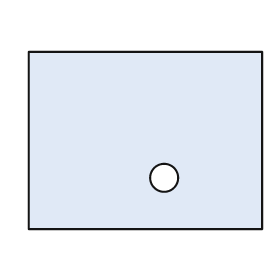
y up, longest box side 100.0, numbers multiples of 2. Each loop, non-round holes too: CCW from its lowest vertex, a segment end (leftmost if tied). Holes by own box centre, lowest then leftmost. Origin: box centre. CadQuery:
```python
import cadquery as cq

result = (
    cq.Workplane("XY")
    .moveTo(-50.0, -38.0)
    .lineTo(50.0, -38.0)
    .lineTo(50.0, 38.0)
    .lineTo(-50.0, 38.0)
    .close()
    .moveTo(8.0, -16.0)
    .circle(6.0)
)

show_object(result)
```